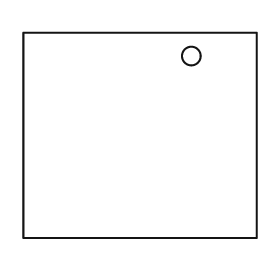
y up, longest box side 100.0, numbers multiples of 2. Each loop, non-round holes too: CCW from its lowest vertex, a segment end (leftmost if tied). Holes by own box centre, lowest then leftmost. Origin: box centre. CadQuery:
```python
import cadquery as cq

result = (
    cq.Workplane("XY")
    .moveTo(-50.0, -44.0)
    .lineTo(50.0, -44.0)
    .lineTo(50.0, 44.0)
    .lineTo(-50.0, 44.0)
    .close()
    .moveTo(22.0, 34.0)
    .circle(4.0)
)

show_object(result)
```